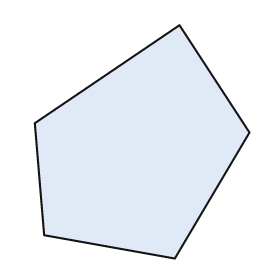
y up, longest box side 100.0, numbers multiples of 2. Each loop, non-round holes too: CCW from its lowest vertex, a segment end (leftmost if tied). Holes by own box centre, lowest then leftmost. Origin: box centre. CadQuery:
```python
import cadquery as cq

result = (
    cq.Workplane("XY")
    .moveTo(14.0, -50.0)
    .lineTo(46.0, 4.0)
    .lineTo(16.0, 50.0)
    .lineTo(-46.0, 8.0)
    .lineTo(-42.0, -40.0)
    .close()
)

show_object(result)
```